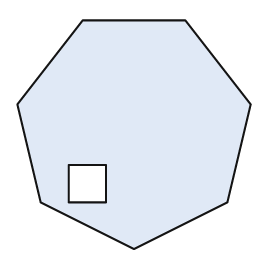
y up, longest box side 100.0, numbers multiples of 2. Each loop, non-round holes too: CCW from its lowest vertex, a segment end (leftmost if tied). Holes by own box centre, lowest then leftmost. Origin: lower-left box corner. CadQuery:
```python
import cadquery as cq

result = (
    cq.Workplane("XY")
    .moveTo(50.0, 0.0)
    .lineTo(90.0, 20.0)
    .lineTo(100.0, 62.0)
    .lineTo(72.0, 98.0)
    .lineTo(28.0, 98.0)
    .lineTo(0.0, 62.0)
    .lineTo(10.0, 20.0)
    .close()
    .moveTo(22.0, 20.0)
    .lineTo(38.0, 20.0)
    .lineTo(38.0, 36.0)
    .lineTo(22.0, 36.0)
    .close()
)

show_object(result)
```